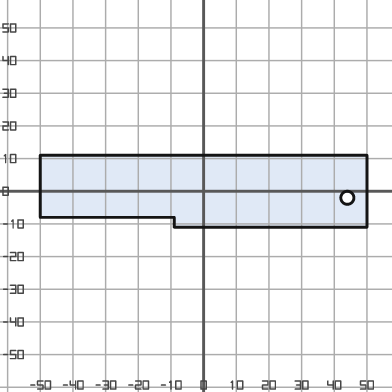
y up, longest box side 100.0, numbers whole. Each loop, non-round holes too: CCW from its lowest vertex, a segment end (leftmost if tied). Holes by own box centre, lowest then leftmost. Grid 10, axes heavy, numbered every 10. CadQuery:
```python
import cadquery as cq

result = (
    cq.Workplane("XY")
    .moveTo(-9.0, -11.0)
    .lineTo(50.0, -11.0)
    .lineTo(50.0, 11.0)
    .lineTo(-50.0, 11.0)
    .lineTo(-50.0, -8.0)
    .lineTo(-9.0, -8.0)
    .close()
    .moveTo(44.0, -2.0)
    .circle(2.0)
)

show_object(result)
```